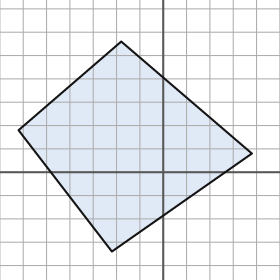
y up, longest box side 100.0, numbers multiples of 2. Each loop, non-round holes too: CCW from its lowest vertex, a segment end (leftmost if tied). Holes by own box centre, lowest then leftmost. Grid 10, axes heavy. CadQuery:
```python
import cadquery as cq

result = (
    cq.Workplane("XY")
    .moveTo(-22.0, -34.0)
    .lineTo(38.0, 8.0)
    .lineTo(-18.0, 56.0)
    .lineTo(-62.0, 18.0)
    .close()
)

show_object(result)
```